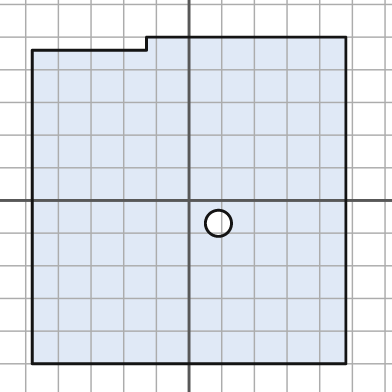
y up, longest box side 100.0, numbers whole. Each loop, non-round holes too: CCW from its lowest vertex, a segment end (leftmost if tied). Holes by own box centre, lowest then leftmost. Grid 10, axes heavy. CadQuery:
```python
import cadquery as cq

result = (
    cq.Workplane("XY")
    .moveTo(-48.0, -50.0)
    .lineTo(48.0, -50.0)
    .lineTo(48.0, 50.0)
    .lineTo(-13.0, 50.0)
    .lineTo(-13.0, 46.0)
    .lineTo(-48.0, 46.0)
    .close()
    .moveTo(9.0, -7.0)
    .circle(4.0)
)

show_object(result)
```